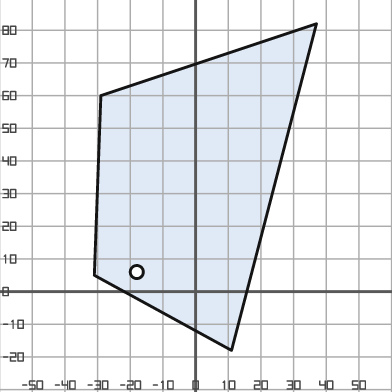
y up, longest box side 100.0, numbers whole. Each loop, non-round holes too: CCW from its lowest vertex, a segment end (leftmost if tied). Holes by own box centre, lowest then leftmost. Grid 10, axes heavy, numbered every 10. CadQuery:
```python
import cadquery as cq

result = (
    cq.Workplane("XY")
    .moveTo(11.0, -18.0)
    .lineTo(37.0, 82.0)
    .lineTo(-29.0, 60.0)
    .lineTo(-31.0, 5.0)
    .close()
    .moveTo(-18.0, 6.0)
    .circle(2.0)
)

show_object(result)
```